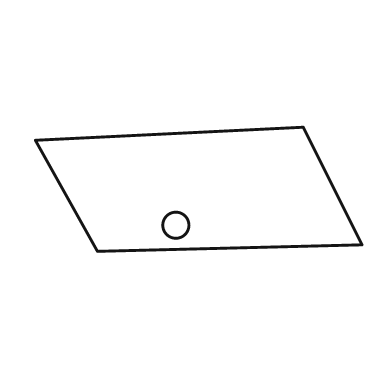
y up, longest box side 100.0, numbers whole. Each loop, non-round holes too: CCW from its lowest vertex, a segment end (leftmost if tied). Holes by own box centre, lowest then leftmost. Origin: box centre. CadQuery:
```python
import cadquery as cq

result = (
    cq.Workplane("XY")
    .moveTo(-31.0, -19.0)
    .lineTo(50.0, -17.0)
    .lineTo(32.0, 19.0)
    .lineTo(-50.0, 15.0)
    .close()
    .moveTo(-7.0, -11.0)
    .circle(4.0)
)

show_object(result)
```